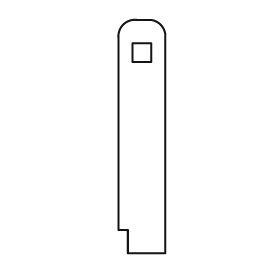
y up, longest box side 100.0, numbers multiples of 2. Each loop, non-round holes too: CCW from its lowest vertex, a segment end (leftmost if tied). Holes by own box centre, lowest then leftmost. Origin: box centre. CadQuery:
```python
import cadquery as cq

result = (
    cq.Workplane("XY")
    .moveTo(-6.0, -50.0)
    .lineTo(10.0, -50.0)
    .lineTo(10.0, 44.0)
    .threePointArc((8.0, 48.0), (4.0, 50.0))
    .lineTo(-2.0, 50.0)
    .threePointArc((-8.0, 48.0), (-10.0, 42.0))
    .lineTo(-10.0, -40.0)
    .lineTo(-6.0, -40.0)
    .close()
    .moveTo(-4.0, 32.0)
    .lineTo(4.0, 32.0)
    .lineTo(4.0, 40.0)
    .lineTo(-4.0, 40.0)
    .close()
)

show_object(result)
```